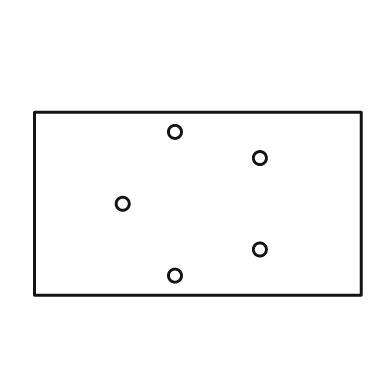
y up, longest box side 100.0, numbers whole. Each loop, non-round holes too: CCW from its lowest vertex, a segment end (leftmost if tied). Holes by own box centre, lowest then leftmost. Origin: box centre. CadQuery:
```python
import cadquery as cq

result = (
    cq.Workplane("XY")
    .moveTo(-50.0, -28.0)
    .lineTo(50.0, -28.0)
    .lineTo(50.0, 28.0)
    .lineTo(-50.0, 28.0)
    .close()
    .moveTo(-7.0, -22.0)
    .circle(2.0)
    .moveTo(19.0, -14.0)
    .circle(2.0)
    .moveTo(-23.0, 0.0)
    .circle(2.0)
    .moveTo(19.0, 14.0)
    .circle(2.0)
    .moveTo(-7.0, 22.0)
    .circle(2.0)
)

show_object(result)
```